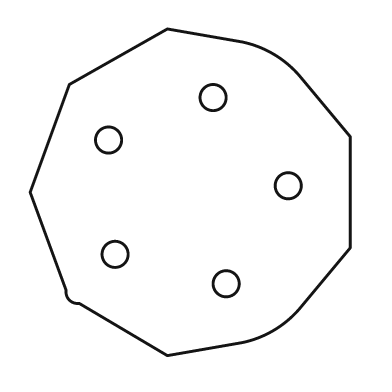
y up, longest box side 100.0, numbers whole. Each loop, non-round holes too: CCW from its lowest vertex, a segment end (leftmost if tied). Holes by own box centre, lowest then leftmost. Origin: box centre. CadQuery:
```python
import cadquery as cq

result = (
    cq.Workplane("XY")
    .moveTo(-7.0, -50.0)
    .lineTo(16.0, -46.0)
    .threePointArc((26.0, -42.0), (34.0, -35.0))
    .lineTo(49.0, -17.0)
    .lineTo(49.0, 17.0)
    .lineTo(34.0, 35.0)
    .threePointArc((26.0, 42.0), (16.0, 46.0))
    .lineTo(-7.0, 50.0)
    .lineTo(-37.0, 33.0)
    .lineTo(-49.0, 0.0)
    .lineTo(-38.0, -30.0)
    .threePointArc((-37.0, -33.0), (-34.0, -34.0))
    .close()
    .moveTo(11.0, -28.0)
    .circle(4.0)
    .moveTo(-23.0, -19.0)
    .circle(4.0)
    .moveTo(30.0, 2.0)
    .circle(4.0)
    .moveTo(-25.0, 16.0)
    .circle(4.0)
    .moveTo(7.0, 29.0)
    .circle(4.0)
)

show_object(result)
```